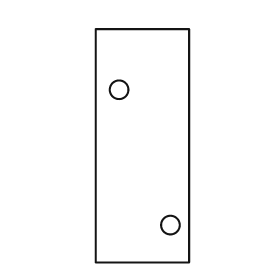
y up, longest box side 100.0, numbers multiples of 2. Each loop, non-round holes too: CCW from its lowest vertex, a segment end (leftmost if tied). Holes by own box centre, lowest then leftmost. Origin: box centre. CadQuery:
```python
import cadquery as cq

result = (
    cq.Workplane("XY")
    .moveTo(-20.0, -50.0)
    .lineTo(20.0, -50.0)
    .lineTo(20.0, 50.0)
    .lineTo(-20.0, 50.0)
    .close()
    .moveTo(12.0, -34.0)
    .circle(4.0)
    .moveTo(-10.0, 24.0)
    .circle(4.0)
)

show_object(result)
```